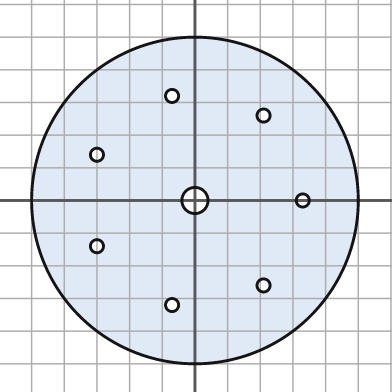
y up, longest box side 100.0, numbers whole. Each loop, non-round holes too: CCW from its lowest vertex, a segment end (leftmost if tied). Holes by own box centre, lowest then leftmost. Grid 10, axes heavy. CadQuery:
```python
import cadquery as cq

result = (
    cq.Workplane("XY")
    .moveTo(0.0, 0.0)
    .circle(50.0)
    .moveTo(-7.0, -32.0)
    .circle(2.0)
    .moveTo(21.0, -26.0)
    .circle(2.0)
    .moveTo(-30.0, -14.0)
    .circle(2.0)
    .moveTo(0.0, 0.0)
    .circle(4.0)
    .moveTo(33.0, 0.0)
    .circle(2.0)
    .moveTo(-30.0, 14.0)
    .circle(2.0)
    .moveTo(21.0, 26.0)
    .circle(2.0)
    .moveTo(-7.0, 32.0)
    .circle(2.0)
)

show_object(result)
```